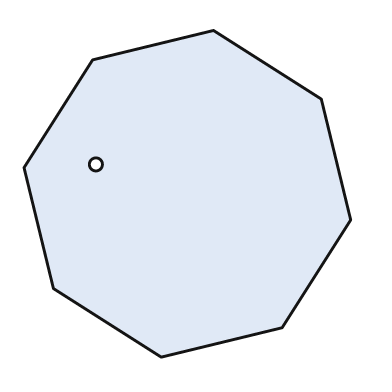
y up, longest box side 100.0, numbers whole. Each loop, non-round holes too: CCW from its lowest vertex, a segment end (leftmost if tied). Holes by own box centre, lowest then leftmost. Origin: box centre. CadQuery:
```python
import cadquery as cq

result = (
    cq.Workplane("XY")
    .moveTo(-8.0, -50.0)
    .lineTo(29.0, -41.0)
    .lineTo(50.0, -8.0)
    .lineTo(41.0, 29.0)
    .lineTo(8.0, 50.0)
    .lineTo(-29.0, 41.0)
    .lineTo(-50.0, 8.0)
    .lineTo(-41.0, -29.0)
    .close()
    .moveTo(-28.0, 9.0)
    .circle(2.0)
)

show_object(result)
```